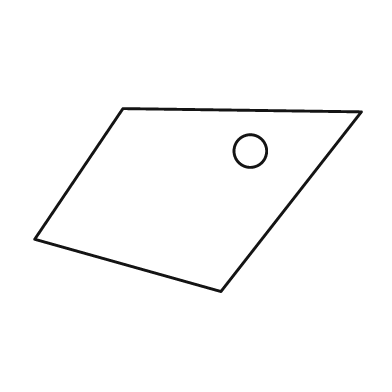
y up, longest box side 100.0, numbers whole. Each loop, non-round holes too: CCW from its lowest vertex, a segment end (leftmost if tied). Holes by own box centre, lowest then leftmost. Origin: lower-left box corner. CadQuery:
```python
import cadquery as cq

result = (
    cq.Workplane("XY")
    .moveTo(57.0, 0.0)
    .lineTo(100.0, 55.0)
    .lineTo(27.0, 56.0)
    .lineTo(0.0, 16.0)
    .close()
    .moveTo(66.0, 43.0)
    .circle(5.0)
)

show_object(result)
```